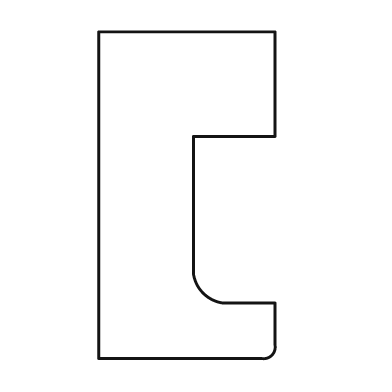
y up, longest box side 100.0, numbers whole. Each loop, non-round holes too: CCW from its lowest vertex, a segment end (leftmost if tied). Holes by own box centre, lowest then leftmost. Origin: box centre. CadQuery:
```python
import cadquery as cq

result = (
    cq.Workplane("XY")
    .moveTo(-27.0, -50.0)
    .lineTo(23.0, -50.0)
    .threePointArc((26.0, -49.0), (27.0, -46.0))
    .lineTo(27.0, -33.0)
    .lineTo(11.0, -33.0)
    .threePointArc((5.0, -30.0), (2.0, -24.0))
    .lineTo(2.0, 18.0)
    .lineTo(27.0, 18.0)
    .lineTo(27.0, 50.0)
    .lineTo(-27.0, 50.0)
    .close()
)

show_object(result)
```